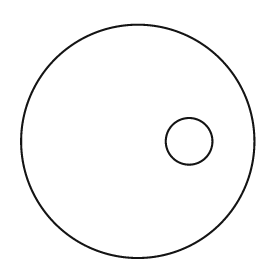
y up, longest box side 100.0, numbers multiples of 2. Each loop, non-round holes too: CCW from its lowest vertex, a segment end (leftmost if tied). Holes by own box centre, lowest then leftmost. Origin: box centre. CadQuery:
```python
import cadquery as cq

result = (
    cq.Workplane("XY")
    .moveTo(0.0, 0.0)
    .circle(50.0)
    .moveTo(22.0, 0.0)
    .circle(10.0)
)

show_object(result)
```